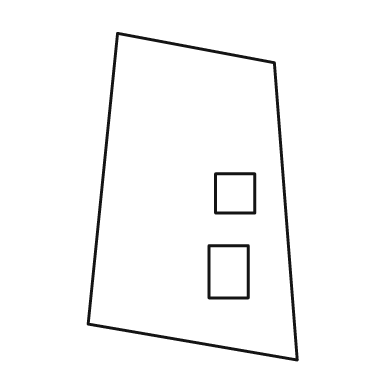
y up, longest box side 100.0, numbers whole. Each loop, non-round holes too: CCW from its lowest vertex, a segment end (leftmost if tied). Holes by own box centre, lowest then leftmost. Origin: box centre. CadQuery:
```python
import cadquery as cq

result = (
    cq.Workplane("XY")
    .moveTo(32.0, -50.0)
    .lineTo(25.0, 41.0)
    .lineTo(-23.0, 50.0)
    .lineTo(-32.0, -39.0)
    .close()
    .moveTo(5.0, -31.0)
    .lineTo(17.0, -31.0)
    .lineTo(17.0, -15.0)
    .lineTo(5.0, -15.0)
    .close()
    .moveTo(7.0, -5.0)
    .lineTo(19.0, -5.0)
    .lineTo(19.0, 7.0)
    .lineTo(7.0, 7.0)
    .close()
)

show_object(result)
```